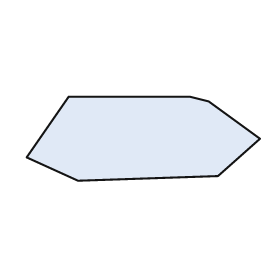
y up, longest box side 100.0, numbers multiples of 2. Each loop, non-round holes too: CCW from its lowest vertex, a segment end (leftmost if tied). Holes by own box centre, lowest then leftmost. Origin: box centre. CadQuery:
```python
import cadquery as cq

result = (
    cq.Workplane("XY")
    .moveTo(-28.0, -18.0)
    .lineTo(32.0, -16.0)
    .lineTo(50.0, 0.0)
    .lineTo(28.0, 16.0)
    .lineTo(20.0, 18.0)
    .lineTo(-32.0, 18.0)
    .lineTo(-50.0, -8.0)
    .close()
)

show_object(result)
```